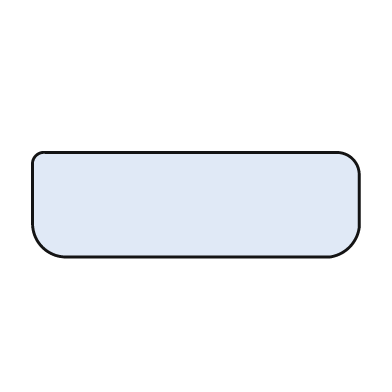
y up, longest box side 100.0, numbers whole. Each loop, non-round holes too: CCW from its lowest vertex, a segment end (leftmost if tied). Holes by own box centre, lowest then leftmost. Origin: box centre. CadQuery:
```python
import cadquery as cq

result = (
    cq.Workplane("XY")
    .moveTo(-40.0, -16.0)
    .lineTo(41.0, -16.0)
    .threePointArc((47.0, -13.0), (50.0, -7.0))
    .lineTo(50.0, 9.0)
    .threePointArc((48.0, 14.0), (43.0, 16.0))
    .lineTo(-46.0, 16.0)
    .threePointArc((-49.0, 15.0), (-50.0, 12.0))
    .lineTo(-50.0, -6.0)
    .threePointArc((-47.0, -13.0), (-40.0, -16.0))
    .close()
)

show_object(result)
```